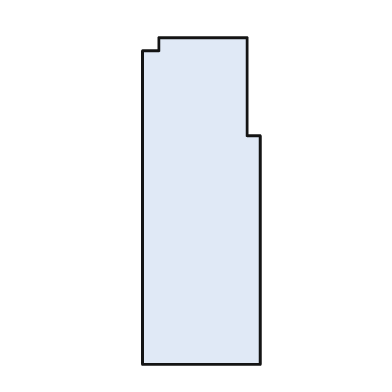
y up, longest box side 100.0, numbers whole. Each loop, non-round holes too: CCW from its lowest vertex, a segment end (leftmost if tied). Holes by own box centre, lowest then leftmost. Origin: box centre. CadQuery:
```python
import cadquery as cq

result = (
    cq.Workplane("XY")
    .moveTo(-18.0, -50.0)
    .lineTo(18.0, -50.0)
    .lineTo(18.0, 20.0)
    .lineTo(14.0, 20.0)
    .lineTo(14.0, 50.0)
    .lineTo(-13.0, 50.0)
    .lineTo(-13.0, 46.0)
    .lineTo(-18.0, 46.0)
    .close()
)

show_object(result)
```